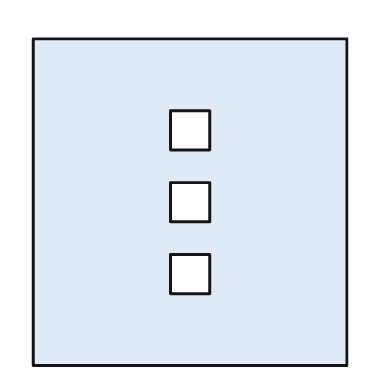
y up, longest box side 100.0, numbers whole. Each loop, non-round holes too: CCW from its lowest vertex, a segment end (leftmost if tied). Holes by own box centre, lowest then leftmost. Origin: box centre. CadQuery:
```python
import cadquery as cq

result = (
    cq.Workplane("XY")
    .moveTo(-48.0, -50.0)
    .lineTo(48.0, -50.0)
    .lineTo(48.0, 50.0)
    .lineTo(-48.0, 50.0)
    .close()
    .moveTo(-6.0, -28.0)
    .lineTo(6.0, -28.0)
    .lineTo(6.0, -16.0)
    .lineTo(-6.0, -16.0)
    .close()
    .moveTo(-6.0, -6.0)
    .lineTo(6.0, -6.0)
    .lineTo(6.0, 6.0)
    .lineTo(-6.0, 6.0)
    .close()
    .moveTo(-6.0, 16.0)
    .lineTo(6.0, 16.0)
    .lineTo(6.0, 28.0)
    .lineTo(-6.0, 28.0)
    .close()
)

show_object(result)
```